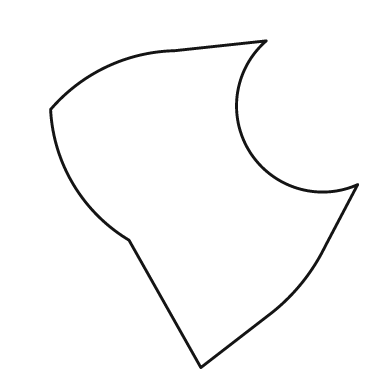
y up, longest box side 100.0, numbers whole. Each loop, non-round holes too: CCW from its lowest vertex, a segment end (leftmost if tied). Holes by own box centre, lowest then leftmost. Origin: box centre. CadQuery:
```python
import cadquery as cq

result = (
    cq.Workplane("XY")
    .moveTo(-1.0, -50.0)
    .lineTo(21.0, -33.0)
    .threePointArc((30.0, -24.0), (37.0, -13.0))
    .lineTo(47.0, 6.0)
    .threePointArc((14.0, 16.0), (19.0, 50.0))
    .lineTo(-9.0, 47.0)
    .threePointArc((-30.0, 42.0), (-47.0, 29.0))
    .threePointArc((-40.0, 6.0), (-23.0, -11.0))
    .close()
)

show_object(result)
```